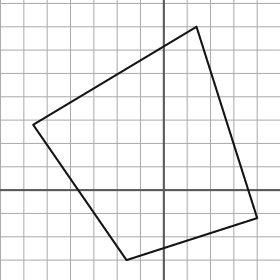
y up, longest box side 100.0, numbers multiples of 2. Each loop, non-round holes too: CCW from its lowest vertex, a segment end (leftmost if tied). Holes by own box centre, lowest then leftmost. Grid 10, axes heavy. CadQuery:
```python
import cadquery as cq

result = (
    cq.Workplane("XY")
    .moveTo(-16.0, -30.0)
    .lineTo(40.0, -12.0)
    .lineTo(14.0, 70.0)
    .lineTo(-56.0, 28.0)
    .close()
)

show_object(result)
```